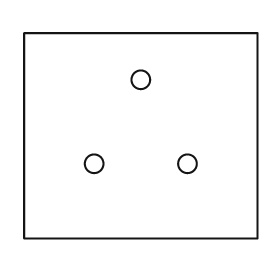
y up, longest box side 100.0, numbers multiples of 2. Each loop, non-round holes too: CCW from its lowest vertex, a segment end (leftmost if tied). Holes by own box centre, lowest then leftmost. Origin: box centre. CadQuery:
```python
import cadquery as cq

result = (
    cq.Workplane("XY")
    .moveTo(-50.0, -44.0)
    .lineTo(50.0, -44.0)
    .lineTo(50.0, 44.0)
    .lineTo(-50.0, 44.0)
    .close()
    .moveTo(-20.0, -12.0)
    .circle(4.0)
    .moveTo(20.0, -12.0)
    .circle(4.0)
    .moveTo(0.0, 24.0)
    .circle(4.0)
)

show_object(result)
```